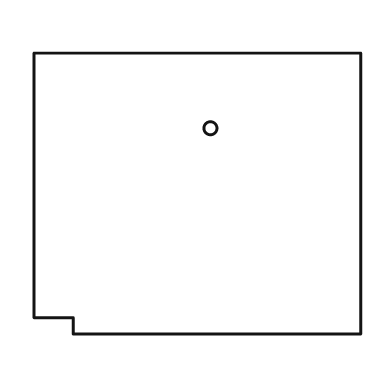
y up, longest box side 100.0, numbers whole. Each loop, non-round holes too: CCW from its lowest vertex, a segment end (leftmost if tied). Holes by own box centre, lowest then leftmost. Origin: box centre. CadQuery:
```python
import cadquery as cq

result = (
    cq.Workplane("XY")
    .moveTo(-38.0, -43.0)
    .lineTo(50.0, -43.0)
    .lineTo(50.0, 43.0)
    .lineTo(-50.0, 43.0)
    .lineTo(-50.0, -38.0)
    .lineTo(-38.0, -38.0)
    .close()
    .moveTo(4.0, 20.0)
    .circle(2.0)
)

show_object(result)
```